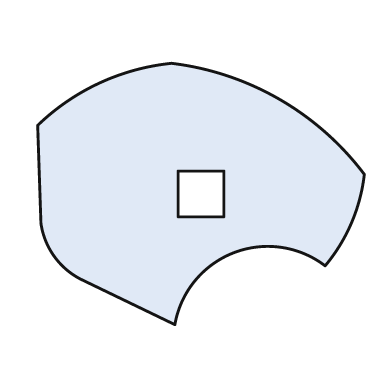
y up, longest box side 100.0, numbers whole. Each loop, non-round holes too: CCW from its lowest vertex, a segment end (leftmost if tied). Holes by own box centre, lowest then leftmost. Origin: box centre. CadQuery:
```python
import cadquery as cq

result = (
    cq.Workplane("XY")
    .moveTo(-8.0, -40.0)
    .threePointArc((10.0, -18.0), (38.0, -22.0))
    .threePointArc((46.0, -9.0), (50.0, 6.0))
    .threePointArc((24.0, 29.0), (-9.0, 40.0))
    .threePointArc((-31.0, 34.0), (-50.0, 21.0))
    .lineTo(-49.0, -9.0)
    .threePointArc((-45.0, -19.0), (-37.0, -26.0))
    .close()
    .moveTo(-7.0, -7.0)
    .lineTo(7.0, -7.0)
    .lineTo(7.0, 7.0)
    .lineTo(-7.0, 7.0)
    .close()
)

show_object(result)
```